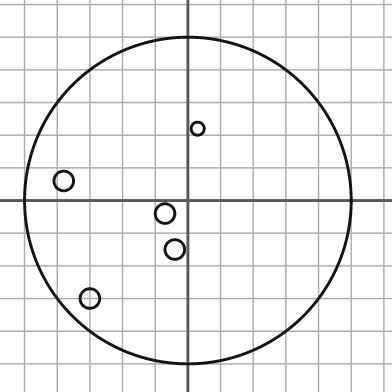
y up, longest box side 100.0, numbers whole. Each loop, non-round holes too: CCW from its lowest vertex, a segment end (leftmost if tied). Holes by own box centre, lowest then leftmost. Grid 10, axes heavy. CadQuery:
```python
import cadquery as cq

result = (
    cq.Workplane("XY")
    .moveTo(0.0, 0.0)
    .circle(50.0)
    .moveTo(-30.0, -30.0)
    .circle(3.0)
    .moveTo(-4.0, -15.0)
    .circle(3.0)
    .moveTo(-7.0, -4.0)
    .circle(3.0)
    .moveTo(-38.0, 6.0)
    .circle(3.0)
    .moveTo(3.0, 22.0)
    .circle(2.0)
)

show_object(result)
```